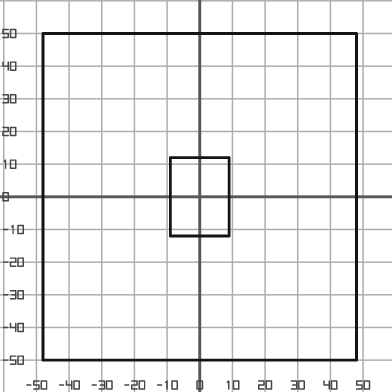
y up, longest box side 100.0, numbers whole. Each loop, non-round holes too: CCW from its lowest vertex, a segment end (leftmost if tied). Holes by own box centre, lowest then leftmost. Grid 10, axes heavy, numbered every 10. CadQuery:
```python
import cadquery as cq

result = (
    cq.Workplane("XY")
    .moveTo(-48.0, -50.0)
    .lineTo(48.0, -50.0)
    .lineTo(48.0, 50.0)
    .lineTo(-48.0, 50.0)
    .close()
    .moveTo(-9.0, -12.0)
    .lineTo(9.0, -12.0)
    .lineTo(9.0, 12.0)
    .lineTo(-9.0, 12.0)
    .close()
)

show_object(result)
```